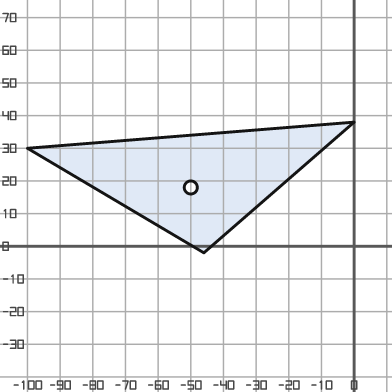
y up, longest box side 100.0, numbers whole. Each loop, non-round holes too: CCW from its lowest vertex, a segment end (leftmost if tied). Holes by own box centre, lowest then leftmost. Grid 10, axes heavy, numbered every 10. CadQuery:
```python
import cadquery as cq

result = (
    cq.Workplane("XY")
    .moveTo(-46.0, -2.0)
    .lineTo(0.0, 38.0)
    .lineTo(-100.0, 30.0)
    .close()
    .moveTo(-50.0, 18.0)
    .circle(2.0)
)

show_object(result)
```